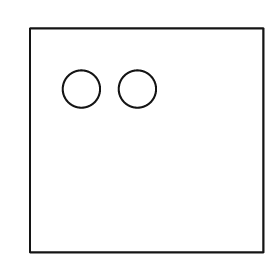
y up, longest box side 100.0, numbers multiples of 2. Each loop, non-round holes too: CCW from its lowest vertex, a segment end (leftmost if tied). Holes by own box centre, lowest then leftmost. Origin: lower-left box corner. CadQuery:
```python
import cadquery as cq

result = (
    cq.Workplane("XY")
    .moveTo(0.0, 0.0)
    .lineTo(100.0, 0.0)
    .lineTo(100.0, 96.0)
    .lineTo(0.0, 96.0)
    .close()
    .moveTo(22.0, 70.0)
    .circle(8.0)
    .moveTo(46.0, 70.0)
    .circle(8.0)
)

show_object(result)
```